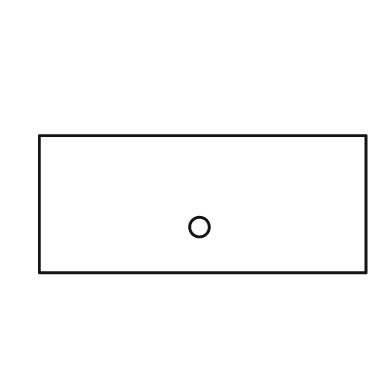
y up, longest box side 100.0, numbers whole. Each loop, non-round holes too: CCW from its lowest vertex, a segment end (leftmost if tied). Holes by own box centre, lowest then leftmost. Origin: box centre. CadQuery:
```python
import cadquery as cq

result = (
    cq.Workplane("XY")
    .moveTo(-50.0, -21.0)
    .lineTo(50.0, -21.0)
    .lineTo(50.0, 21.0)
    .lineTo(-50.0, 21.0)
    .close()
    .moveTo(-1.0, -7.0)
    .circle(3.0)
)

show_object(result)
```